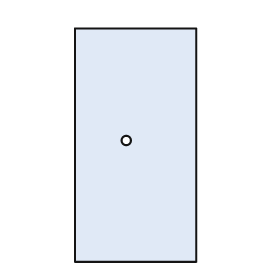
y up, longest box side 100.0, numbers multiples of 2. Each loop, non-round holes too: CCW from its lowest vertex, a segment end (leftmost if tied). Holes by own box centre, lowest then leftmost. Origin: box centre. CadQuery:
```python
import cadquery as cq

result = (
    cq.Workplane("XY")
    .moveTo(-26.0, -50.0)
    .lineTo(26.0, -50.0)
    .lineTo(26.0, 50.0)
    .lineTo(-26.0, 50.0)
    .close()
    .moveTo(-4.0, 2.0)
    .circle(2.0)
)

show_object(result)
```